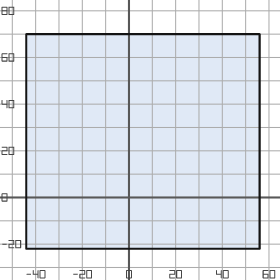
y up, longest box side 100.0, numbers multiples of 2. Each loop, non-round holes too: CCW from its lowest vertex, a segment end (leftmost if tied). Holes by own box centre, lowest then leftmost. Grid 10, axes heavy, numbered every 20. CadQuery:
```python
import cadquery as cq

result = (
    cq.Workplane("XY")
    .moveTo(-44.0, -22.0)
    .lineTo(56.0, -22.0)
    .lineTo(56.0, 70.0)
    .lineTo(-44.0, 70.0)
    .close()
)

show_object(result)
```